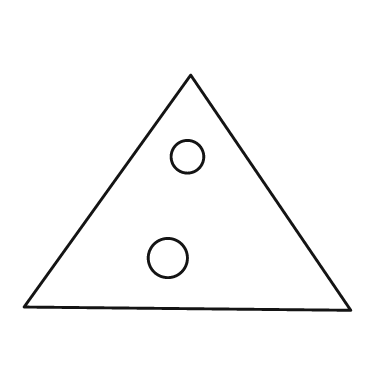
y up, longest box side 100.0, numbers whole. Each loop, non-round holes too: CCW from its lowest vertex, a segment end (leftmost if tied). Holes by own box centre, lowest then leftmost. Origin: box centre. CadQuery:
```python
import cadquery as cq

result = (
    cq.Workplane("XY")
    .moveTo(50.0, -36.0)
    .lineTo(1.0, 36.0)
    .lineTo(-50.0, -35.0)
    .close()
    .moveTo(-6.0, -20.0)
    .circle(6.0)
    .moveTo(0.0, 11.0)
    .circle(5.0)
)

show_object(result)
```